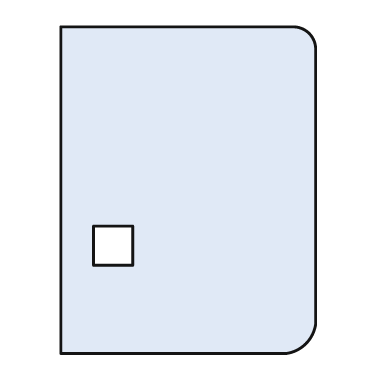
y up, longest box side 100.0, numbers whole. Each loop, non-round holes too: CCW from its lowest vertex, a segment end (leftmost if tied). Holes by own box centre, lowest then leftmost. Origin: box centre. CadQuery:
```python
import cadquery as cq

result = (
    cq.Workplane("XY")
    .moveTo(-39.0, -50.0)
    .lineTo(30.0, -50.0)
    .threePointArc((36.0, -47.0), (39.0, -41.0))
    .lineTo(39.0, 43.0)
    .threePointArc((37.0, 48.0), (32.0, 50.0))
    .lineTo(-39.0, 50.0)
    .close()
    .moveTo(-29.0, -23.0)
    .lineTo(-17.0, -23.0)
    .lineTo(-17.0, -11.0)
    .lineTo(-29.0, -11.0)
    .close()
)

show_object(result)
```